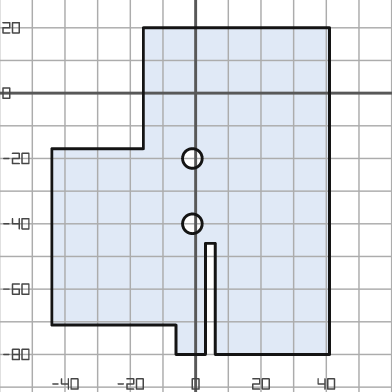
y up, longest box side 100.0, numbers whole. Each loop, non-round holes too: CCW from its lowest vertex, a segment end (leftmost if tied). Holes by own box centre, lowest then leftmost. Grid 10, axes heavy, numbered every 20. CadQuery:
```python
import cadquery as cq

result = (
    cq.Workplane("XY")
    .moveTo(-6.0, -80.0)
    .lineTo(3.0, -80.0)
    .lineTo(3.0, -46.0)
    .lineTo(6.0, -46.0)
    .lineTo(6.0, -80.0)
    .lineTo(41.0, -80.0)
    .lineTo(41.0, 20.0)
    .lineTo(-16.0, 20.0)
    .lineTo(-16.0, -17.0)
    .lineTo(-44.0, -17.0)
    .lineTo(-44.0, -71.0)
    .lineTo(-6.0, -71.0)
    .close()
    .moveTo(-1.0, -40.0)
    .circle(3.0)
    .moveTo(-1.0, -20.0)
    .circle(3.0)
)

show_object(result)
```